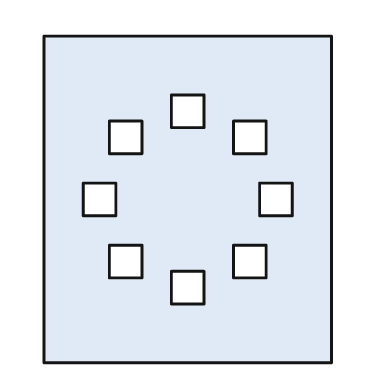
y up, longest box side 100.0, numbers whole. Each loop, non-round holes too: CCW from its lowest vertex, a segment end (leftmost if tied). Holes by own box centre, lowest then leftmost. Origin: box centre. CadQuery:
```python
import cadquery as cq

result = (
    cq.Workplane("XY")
    .moveTo(-44.0, -50.0)
    .lineTo(44.0, -50.0)
    .lineTo(44.0, 50.0)
    .lineTo(-44.0, 50.0)
    .close()
    .moveTo(-5.0, -32.0)
    .lineTo(5.0, -32.0)
    .lineTo(5.0, -22.0)
    .lineTo(-5.0, -22.0)
    .close()
    .moveTo(-24.0, -24.0)
    .lineTo(-14.0, -24.0)
    .lineTo(-14.0, -14.0)
    .lineTo(-24.0, -14.0)
    .close()
    .moveTo(14.0, -24.0)
    .lineTo(24.0, -24.0)
    .lineTo(24.0, -14.0)
    .lineTo(14.0, -14.0)
    .close()
    .moveTo(-32.0, -5.0)
    .lineTo(-22.0, -5.0)
    .lineTo(-22.0, 5.0)
    .lineTo(-32.0, 5.0)
    .close()
    .moveTo(22.0, -5.0)
    .lineTo(32.0, -5.0)
    .lineTo(32.0, 5.0)
    .lineTo(22.0, 5.0)
    .close()
    .moveTo(-24.0, 14.0)
    .lineTo(-14.0, 14.0)
    .lineTo(-14.0, 24.0)
    .lineTo(-24.0, 24.0)
    .close()
    .moveTo(14.0, 14.0)
    .lineTo(24.0, 14.0)
    .lineTo(24.0, 24.0)
    .lineTo(14.0, 24.0)
    .close()
    .moveTo(-5.0, 22.0)
    .lineTo(5.0, 22.0)
    .lineTo(5.0, 32.0)
    .lineTo(-5.0, 32.0)
    .close()
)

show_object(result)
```